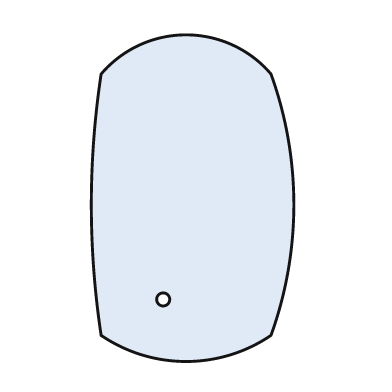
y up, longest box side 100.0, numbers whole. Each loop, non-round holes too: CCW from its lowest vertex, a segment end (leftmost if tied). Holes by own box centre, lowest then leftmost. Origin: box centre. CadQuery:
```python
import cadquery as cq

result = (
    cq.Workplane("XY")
    .moveTo(-28.0, -42.0)
    .threePointArc((-2.0, -50.0), (24.0, -42.0))
    .threePointArc((31.0, -2.0), (24.0, 38.0))
    .threePointArc((-2.0, 50.0), (-28.0, 38.0))
    .threePointArc((-31.0, -2.0), (-28.0, -42.0))
    .close()
    .moveTo(-9.0, -31.0)
    .circle(2.0)
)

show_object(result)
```